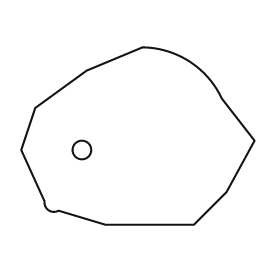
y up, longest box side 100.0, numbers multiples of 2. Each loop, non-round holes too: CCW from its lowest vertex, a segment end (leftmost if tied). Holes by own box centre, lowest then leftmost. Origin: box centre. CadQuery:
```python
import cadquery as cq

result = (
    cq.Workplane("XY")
    .moveTo(-14.0, -38.0)
    .lineTo(24.0, -38.0)
    .lineTo(38.0, -24.0)
    .lineTo(50.0, -2.0)
    .lineTo(36.0, 16.0)
    .threePointArc((22.0, 32.0), (2.0, 38.0))
    .lineTo(-22.0, 28.0)
    .lineTo(-44.0, 12.0)
    .lineTo(-50.0, -6.0)
    .lineTo(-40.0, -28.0)
    .threePointArc((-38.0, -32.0), (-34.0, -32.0))
    .close()
    .moveTo(-24.0, -6.0)
    .circle(4.0)
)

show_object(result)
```